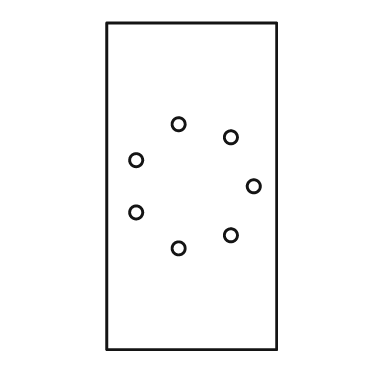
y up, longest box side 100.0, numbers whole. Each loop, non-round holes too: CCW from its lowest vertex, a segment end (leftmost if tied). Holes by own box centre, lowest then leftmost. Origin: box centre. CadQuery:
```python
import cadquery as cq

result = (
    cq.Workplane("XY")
    .moveTo(-26.0, -50.0)
    .lineTo(26.0, -50.0)
    .lineTo(26.0, 50.0)
    .lineTo(-26.0, 50.0)
    .close()
    .moveTo(-4.0, -19.0)
    .circle(2.0)
    .moveTo(12.0, -15.0)
    .circle(2.0)
    .moveTo(-17.0, -8.0)
    .circle(2.0)
    .moveTo(19.0, 0.0)
    .circle(2.0)
    .moveTo(-17.0, 8.0)
    .circle(2.0)
    .moveTo(12.0, 15.0)
    .circle(2.0)
    .moveTo(-4.0, 19.0)
    .circle(2.0)
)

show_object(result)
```